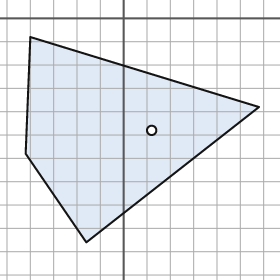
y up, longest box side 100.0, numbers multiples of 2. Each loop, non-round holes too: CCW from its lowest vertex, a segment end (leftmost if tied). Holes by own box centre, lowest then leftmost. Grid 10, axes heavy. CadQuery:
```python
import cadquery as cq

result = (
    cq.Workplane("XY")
    .moveTo(-16.0, -96.0)
    .lineTo(58.0, -38.0)
    .lineTo(-40.0, -8.0)
    .lineTo(-42.0, -58.0)
    .close()
    .moveTo(12.0, -48.0)
    .circle(2.0)
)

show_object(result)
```